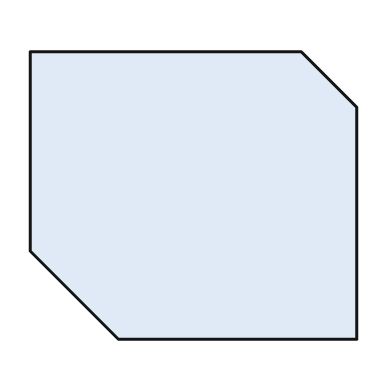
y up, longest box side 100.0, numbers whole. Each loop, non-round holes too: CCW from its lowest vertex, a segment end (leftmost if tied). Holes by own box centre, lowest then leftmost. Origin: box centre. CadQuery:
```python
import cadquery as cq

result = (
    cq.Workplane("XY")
    .moveTo(-23.0, -44.0)
    .lineTo(50.0, -44.0)
    .lineTo(50.0, 27.0)
    .lineTo(33.0, 44.0)
    .lineTo(-50.0, 44.0)
    .lineTo(-50.0, -17.0)
    .close()
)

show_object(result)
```